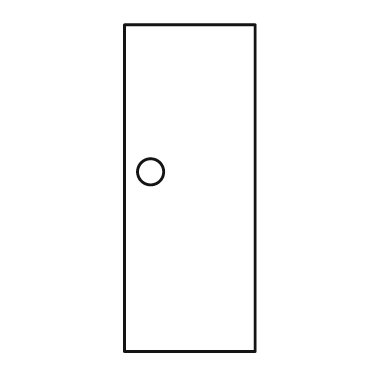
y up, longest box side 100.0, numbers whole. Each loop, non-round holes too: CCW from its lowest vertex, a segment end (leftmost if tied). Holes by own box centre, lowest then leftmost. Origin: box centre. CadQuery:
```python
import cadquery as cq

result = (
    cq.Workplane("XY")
    .moveTo(-20.0, -50.0)
    .lineTo(20.0, -50.0)
    .lineTo(20.0, 50.0)
    .lineTo(-20.0, 50.0)
    .close()
    .moveTo(-12.0, 5.0)
    .circle(4.0)
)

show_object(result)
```